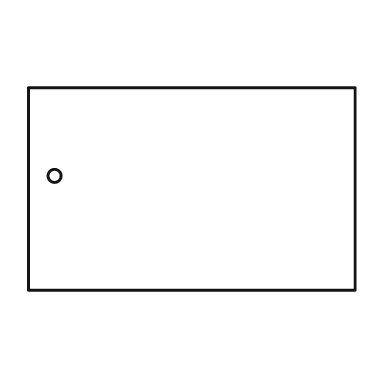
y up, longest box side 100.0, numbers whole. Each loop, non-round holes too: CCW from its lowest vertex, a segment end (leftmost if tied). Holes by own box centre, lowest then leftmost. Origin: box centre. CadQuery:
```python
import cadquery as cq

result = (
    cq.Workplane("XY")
    .moveTo(-50.0, -31.0)
    .lineTo(50.0, -31.0)
    .lineTo(50.0, 31.0)
    .lineTo(-50.0, 31.0)
    .close()
    .moveTo(-42.0, 4.0)
    .circle(2.0)
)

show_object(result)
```